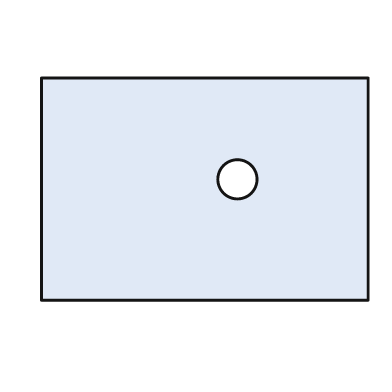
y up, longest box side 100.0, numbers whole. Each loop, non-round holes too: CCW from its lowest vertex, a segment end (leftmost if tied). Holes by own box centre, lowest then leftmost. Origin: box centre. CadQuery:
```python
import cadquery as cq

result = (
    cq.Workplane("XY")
    .moveTo(-50.0, -34.0)
    .lineTo(50.0, -34.0)
    .lineTo(50.0, 34.0)
    .lineTo(-50.0, 34.0)
    .close()
    .moveTo(10.0, 3.0)
    .circle(6.0)
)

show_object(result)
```